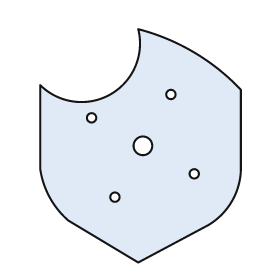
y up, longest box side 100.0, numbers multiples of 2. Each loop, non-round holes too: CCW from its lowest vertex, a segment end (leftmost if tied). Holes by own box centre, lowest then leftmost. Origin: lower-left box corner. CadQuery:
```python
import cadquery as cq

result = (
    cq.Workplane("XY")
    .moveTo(42.0, 0.0)
    .lineTo(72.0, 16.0)
    .threePointArc((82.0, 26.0), (86.0, 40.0))
    .lineTo(86.0, 74.0)
    .threePointArc((66.0, 90.0), (42.0, 100.0))
    .threePointArc((30.0, 72.0), (0.0, 76.0))
    .lineTo(0.0, 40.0)
    .threePointArc((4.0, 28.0), (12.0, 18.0))
    .close()
    .moveTo(32.0, 28.0)
    .circle(2.0)
    .moveTo(66.0, 38.0)
    .circle(2.0)
    .moveTo(44.0, 50.0)
    .circle(4.0)
    .moveTo(22.0, 62.0)
    .circle(2.0)
    .moveTo(56.0, 72.0)
    .circle(2.0)
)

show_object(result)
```